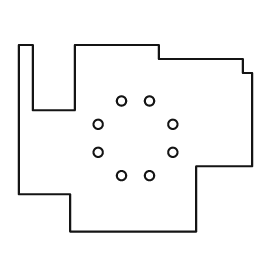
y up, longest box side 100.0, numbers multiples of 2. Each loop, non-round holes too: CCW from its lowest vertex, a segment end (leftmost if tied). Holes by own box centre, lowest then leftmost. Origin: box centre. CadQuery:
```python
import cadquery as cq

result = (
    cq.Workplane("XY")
    .moveTo(-28.0, -40.0)
    .lineTo(26.0, -40.0)
    .lineTo(26.0, -12.0)
    .lineTo(50.0, -12.0)
    .lineTo(50.0, 28.0)
    .lineTo(46.0, 28.0)
    .lineTo(46.0, 34.0)
    .lineTo(10.0, 34.0)
    .lineTo(10.0, 40.0)
    .lineTo(-26.0, 40.0)
    .lineTo(-26.0, 12.0)
    .lineTo(-44.0, 12.0)
    .lineTo(-44.0, 40.0)
    .lineTo(-50.0, 40.0)
    .lineTo(-50.0, -24.0)
    .lineTo(-28.0, -24.0)
    .close()
    .moveTo(-6.0, -16.0)
    .circle(2.0)
    .moveTo(6.0, -16.0)
    .circle(2.0)
    .moveTo(-16.0, -6.0)
    .circle(2.0)
    .moveTo(16.0, -6.0)
    .circle(2.0)
    .moveTo(-16.0, 6.0)
    .circle(2.0)
    .moveTo(16.0, 6.0)
    .circle(2.0)
    .moveTo(-6.0, 16.0)
    .circle(2.0)
    .moveTo(6.0, 16.0)
    .circle(2.0)
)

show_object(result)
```